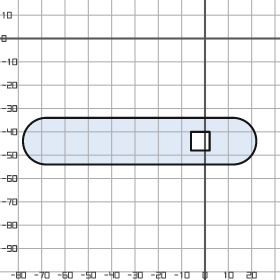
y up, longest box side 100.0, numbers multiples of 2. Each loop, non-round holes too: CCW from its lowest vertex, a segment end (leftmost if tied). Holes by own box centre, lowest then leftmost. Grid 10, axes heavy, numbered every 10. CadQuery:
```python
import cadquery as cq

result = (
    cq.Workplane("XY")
    .moveTo(-68.0, -54.0)
    .lineTo(12.0, -54.0)
    .threePointArc((22.0, -44.0), (12.0, -34.0))
    .lineTo(-68.0, -34.0)
    .threePointArc((-78.0, -44.0), (-68.0, -54.0))
    .close()
    .moveTo(-6.0, -48.0)
    .lineTo(2.0, -48.0)
    .lineTo(2.0, -40.0)
    .lineTo(-6.0, -40.0)
    .close()
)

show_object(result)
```